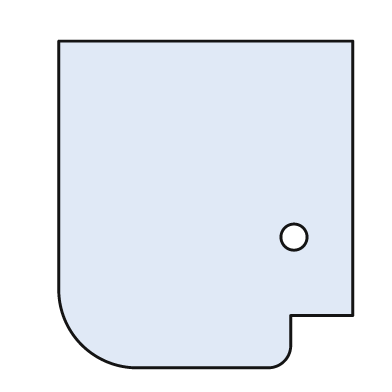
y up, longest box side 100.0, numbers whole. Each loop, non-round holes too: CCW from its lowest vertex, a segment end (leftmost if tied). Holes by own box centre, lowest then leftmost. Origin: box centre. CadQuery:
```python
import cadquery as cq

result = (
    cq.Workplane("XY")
    .moveTo(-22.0, -50.0)
    .lineTo(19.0, -50.0)
    .threePointArc((24.0, -48.0), (26.0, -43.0))
    .lineTo(26.0, -34.0)
    .lineTo(45.0, -34.0)
    .lineTo(45.0, 50.0)
    .lineTo(-45.0, 50.0)
    .lineTo(-45.0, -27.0)
    .threePointArc((-38.0, -43.0), (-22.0, -50.0))
    .close()
    .moveTo(27.0, -10.0)
    .circle(4.0)
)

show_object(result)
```